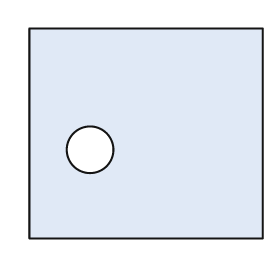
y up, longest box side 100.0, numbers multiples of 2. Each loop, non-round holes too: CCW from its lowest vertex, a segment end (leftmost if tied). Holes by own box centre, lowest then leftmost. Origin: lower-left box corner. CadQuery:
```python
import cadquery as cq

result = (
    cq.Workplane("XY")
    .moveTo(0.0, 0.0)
    .lineTo(100.0, 0.0)
    .lineTo(100.0, 90.0)
    .lineTo(0.0, 90.0)
    .close()
    .moveTo(26.0, 38.0)
    .circle(10.0)
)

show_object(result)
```